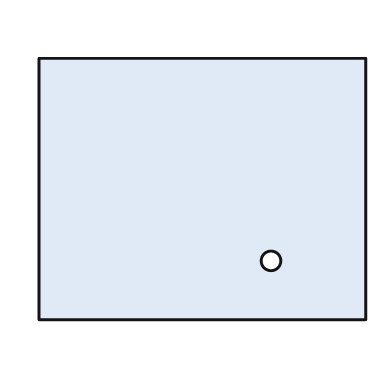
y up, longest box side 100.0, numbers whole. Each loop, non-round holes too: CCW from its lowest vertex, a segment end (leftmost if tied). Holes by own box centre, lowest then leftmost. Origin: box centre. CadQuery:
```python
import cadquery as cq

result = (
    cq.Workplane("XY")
    .moveTo(-50.0, -40.0)
    .lineTo(50.0, -40.0)
    .lineTo(50.0, 40.0)
    .lineTo(-50.0, 40.0)
    .close()
    .moveTo(21.0, -22.0)
    .circle(3.0)
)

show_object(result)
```